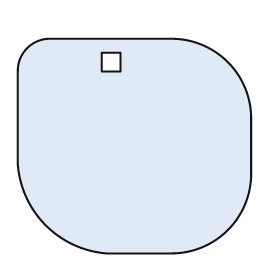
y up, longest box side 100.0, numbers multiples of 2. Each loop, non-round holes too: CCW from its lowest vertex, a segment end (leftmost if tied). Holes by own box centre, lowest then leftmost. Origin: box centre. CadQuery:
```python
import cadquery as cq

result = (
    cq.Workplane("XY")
    .moveTo(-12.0, -46.0)
    .lineTo(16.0, -46.0)
    .threePointArc((40.0, -36.0), (50.0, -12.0))
    .lineTo(50.0, 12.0)
    .threePointArc((40.0, 36.0), (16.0, 46.0))
    .lineTo(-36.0, 46.0)
    .threePointArc((-46.0, 42.0), (-50.0, 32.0))
    .lineTo(-50.0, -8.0)
    .threePointArc((-38.0, -34.0), (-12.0, -46.0))
    .close()
    .moveTo(-14.0, 32.0)
    .lineTo(-6.0, 32.0)
    .lineTo(-6.0, 40.0)
    .lineTo(-14.0, 40.0)
    .close()
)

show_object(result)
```